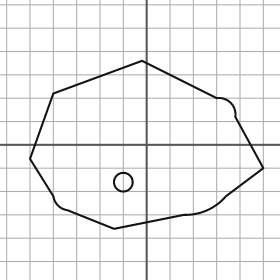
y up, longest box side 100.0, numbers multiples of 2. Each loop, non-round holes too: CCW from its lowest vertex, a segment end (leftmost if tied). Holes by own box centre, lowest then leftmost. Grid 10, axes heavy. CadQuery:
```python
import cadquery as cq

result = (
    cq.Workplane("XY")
    .moveTo(-14.0, -36.0)
    .lineTo(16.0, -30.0)
    .threePointArc((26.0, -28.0), (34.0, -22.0))
    .lineTo(50.0, -10.0)
    .lineTo(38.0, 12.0)
    .threePointArc((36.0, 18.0), (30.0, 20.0))
    .lineTo(-2.0, 36.0)
    .lineTo(-40.0, 22.0)
    .lineTo(-50.0, -6.0)
    .lineTo(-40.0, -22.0)
    .threePointArc((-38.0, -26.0), (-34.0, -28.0))
    .close()
    .moveTo(-10.0, -16.0)
    .circle(4.0)
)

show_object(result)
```